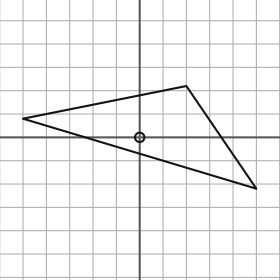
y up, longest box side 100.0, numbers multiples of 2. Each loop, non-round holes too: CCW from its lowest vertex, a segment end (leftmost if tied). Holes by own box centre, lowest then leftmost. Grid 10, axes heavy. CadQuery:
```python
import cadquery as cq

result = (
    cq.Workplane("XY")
    .moveTo(50.0, -22.0)
    .lineTo(20.0, 22.0)
    .lineTo(-50.0, 8.0)
    .close()
    .moveTo(0.0, 0.0)
    .circle(2.0)
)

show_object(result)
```